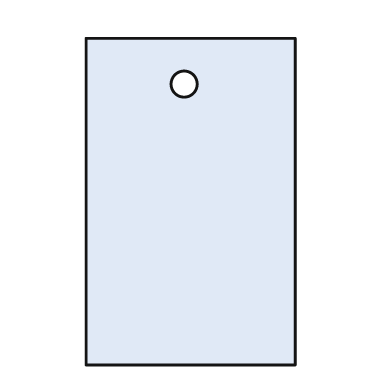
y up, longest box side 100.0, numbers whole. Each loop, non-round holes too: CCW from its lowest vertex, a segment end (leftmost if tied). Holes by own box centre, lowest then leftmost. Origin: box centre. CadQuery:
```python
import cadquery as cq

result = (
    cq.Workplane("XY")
    .moveTo(-32.0, -50.0)
    .lineTo(32.0, -50.0)
    .lineTo(32.0, 50.0)
    .lineTo(-32.0, 50.0)
    .close()
    .moveTo(-2.0, 36.0)
    .circle(4.0)
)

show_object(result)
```